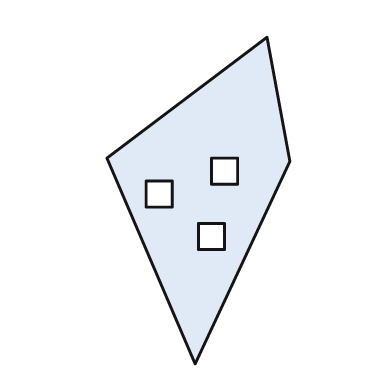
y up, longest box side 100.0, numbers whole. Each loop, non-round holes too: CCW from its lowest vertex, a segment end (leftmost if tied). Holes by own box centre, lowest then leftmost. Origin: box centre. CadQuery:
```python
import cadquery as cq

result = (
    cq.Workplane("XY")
    .moveTo(-1.0, -50.0)
    .lineTo(28.0, 12.0)
    .lineTo(21.0, 50.0)
    .lineTo(-28.0, 13.0)
    .close()
    .moveTo(0.0, -15.0)
    .lineTo(8.0, -15.0)
    .lineTo(8.0, -7.0)
    .lineTo(0.0, -7.0)
    .close()
    .moveTo(-16.0, -2.0)
    .lineTo(-8.0, -2.0)
    .lineTo(-8.0, 6.0)
    .lineTo(-16.0, 6.0)
    .close()
    .moveTo(4.0, 5.0)
    .lineTo(12.0, 5.0)
    .lineTo(12.0, 13.0)
    .lineTo(4.0, 13.0)
    .close()
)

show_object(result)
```